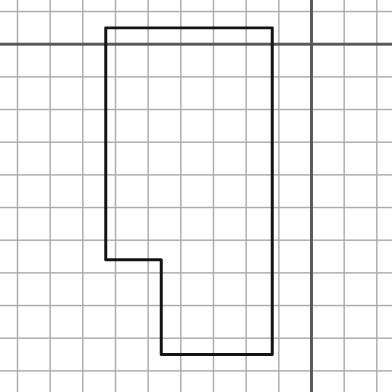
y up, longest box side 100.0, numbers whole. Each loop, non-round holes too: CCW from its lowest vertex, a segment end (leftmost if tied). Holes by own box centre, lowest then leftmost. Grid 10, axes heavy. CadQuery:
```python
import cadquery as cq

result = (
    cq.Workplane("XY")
    .moveTo(-46.0, -95.0)
    .lineTo(-12.0, -95.0)
    .lineTo(-12.0, 5.0)
    .lineTo(-63.0, 5.0)
    .lineTo(-63.0, -66.0)
    .lineTo(-46.0, -66.0)
    .close()
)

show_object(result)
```